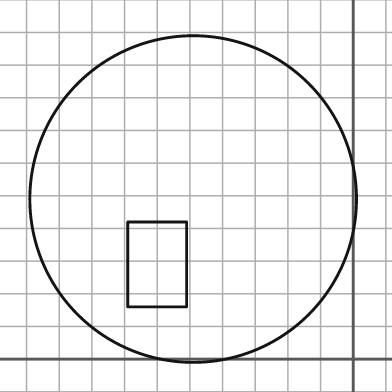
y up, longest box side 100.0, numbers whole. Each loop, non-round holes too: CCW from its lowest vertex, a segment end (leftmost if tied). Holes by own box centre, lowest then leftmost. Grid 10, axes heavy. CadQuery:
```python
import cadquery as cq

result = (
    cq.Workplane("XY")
    .moveTo(-49.0, 49.0)
    .circle(50.0)
    .moveTo(-69.0, 16.0)
    .lineTo(-51.0, 16.0)
    .lineTo(-51.0, 42.0)
    .lineTo(-69.0, 42.0)
    .close()
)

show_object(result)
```